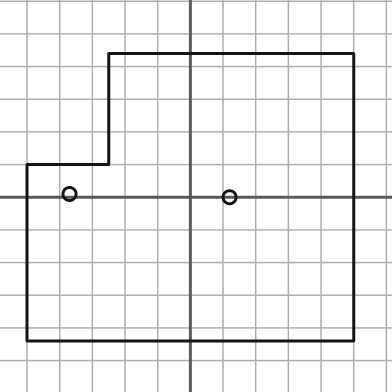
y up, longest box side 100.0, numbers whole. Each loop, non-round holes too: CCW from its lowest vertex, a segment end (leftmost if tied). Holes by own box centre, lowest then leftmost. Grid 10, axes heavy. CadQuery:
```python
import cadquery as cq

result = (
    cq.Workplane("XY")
    .moveTo(-50.0, -44.0)
    .lineTo(50.0, -44.0)
    .lineTo(50.0, 44.0)
    .lineTo(-25.0, 44.0)
    .lineTo(-25.0, 10.0)
    .lineTo(-50.0, 10.0)
    .close()
    .moveTo(12.0, 0.0)
    .circle(2.0)
    .moveTo(-37.0, 1.0)
    .circle(2.0)
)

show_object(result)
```